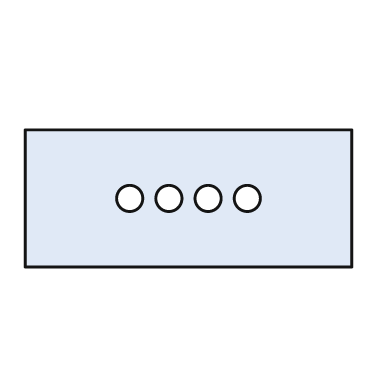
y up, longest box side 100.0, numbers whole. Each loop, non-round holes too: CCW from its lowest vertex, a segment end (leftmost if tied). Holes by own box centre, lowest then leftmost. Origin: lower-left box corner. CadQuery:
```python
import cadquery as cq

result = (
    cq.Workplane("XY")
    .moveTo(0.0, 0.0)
    .lineTo(100.0, 0.0)
    .lineTo(100.0, 42.0)
    .lineTo(0.0, 42.0)
    .close()
    .moveTo(32.0, 21.0)
    .circle(4.0)
    .moveTo(44.0, 21.0)
    .circle(4.0)
    .moveTo(56.0, 21.0)
    .circle(4.0)
    .moveTo(68.0, 21.0)
    .circle(4.0)
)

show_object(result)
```